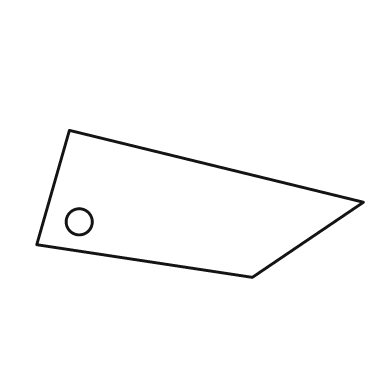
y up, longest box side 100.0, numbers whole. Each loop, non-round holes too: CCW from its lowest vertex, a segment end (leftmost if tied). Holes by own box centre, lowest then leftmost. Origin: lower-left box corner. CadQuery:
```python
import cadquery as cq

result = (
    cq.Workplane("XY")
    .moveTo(66.0, 0.0)
    .lineTo(100.0, 23.0)
    .lineTo(10.0, 45.0)
    .lineTo(0.0, 10.0)
    .close()
    .moveTo(13.0, 17.0)
    .circle(4.0)
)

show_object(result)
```